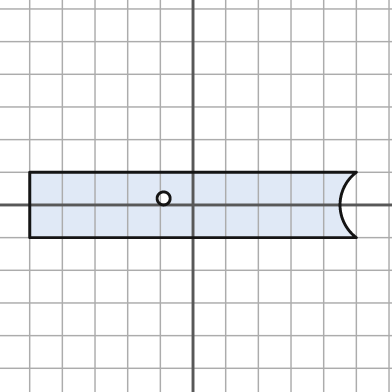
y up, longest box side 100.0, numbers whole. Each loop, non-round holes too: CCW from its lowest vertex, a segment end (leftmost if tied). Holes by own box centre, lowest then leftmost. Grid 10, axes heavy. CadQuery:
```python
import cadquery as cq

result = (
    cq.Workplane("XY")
    .moveTo(-50.0, -10.0)
    .lineTo(50.0, -10.0)
    .threePointArc((45.0, 0.0), (50.0, 10.0))
    .lineTo(-50.0, 10.0)
    .close()
    .moveTo(-9.0, 2.0)
    .circle(2.0)
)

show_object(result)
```